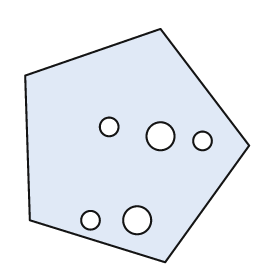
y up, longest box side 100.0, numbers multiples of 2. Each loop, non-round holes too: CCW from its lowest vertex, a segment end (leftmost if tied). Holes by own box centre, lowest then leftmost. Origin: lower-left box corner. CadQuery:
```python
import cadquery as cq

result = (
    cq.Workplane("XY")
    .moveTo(60.0, 0.0)
    .lineTo(96.0, 50.0)
    .lineTo(58.0, 100.0)
    .lineTo(0.0, 80.0)
    .lineTo(2.0, 18.0)
    .close()
    .moveTo(28.0, 18.0)
    .circle(4.0)
    .moveTo(48.0, 18.0)
    .circle(6.0)
    .moveTo(76.0, 52.0)
    .circle(4.0)
    .moveTo(58.0, 54.0)
    .circle(6.0)
    .moveTo(36.0, 58.0)
    .circle(4.0)
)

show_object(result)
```